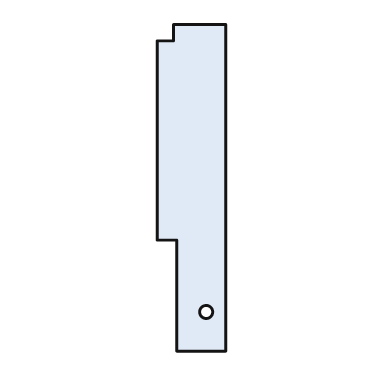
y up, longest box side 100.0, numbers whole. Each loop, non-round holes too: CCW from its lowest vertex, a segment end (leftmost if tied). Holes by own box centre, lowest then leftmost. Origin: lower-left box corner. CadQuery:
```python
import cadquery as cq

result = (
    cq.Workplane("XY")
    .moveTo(6.0, 0.0)
    .lineTo(21.0, 0.0)
    .lineTo(21.0, 100.0)
    .lineTo(5.0, 100.0)
    .lineTo(5.0, 95.0)
    .lineTo(0.0, 95.0)
    .lineTo(0.0, 34.0)
    .lineTo(6.0, 34.0)
    .close()
    .moveTo(15.0, 12.0)
    .circle(2.0)
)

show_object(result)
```